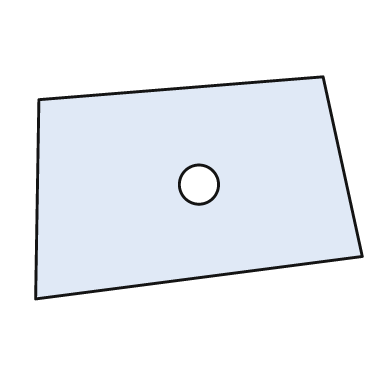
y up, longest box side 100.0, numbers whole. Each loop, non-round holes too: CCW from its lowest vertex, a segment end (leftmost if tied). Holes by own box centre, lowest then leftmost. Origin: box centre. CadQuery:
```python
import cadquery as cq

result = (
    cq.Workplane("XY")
    .moveTo(-50.0, -34.0)
    .lineTo(50.0, -21.0)
    .lineTo(38.0, 34.0)
    .lineTo(-49.0, 27.0)
    .close()
    .moveTo(0.0, 1.0)
    .circle(6.0)
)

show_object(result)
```